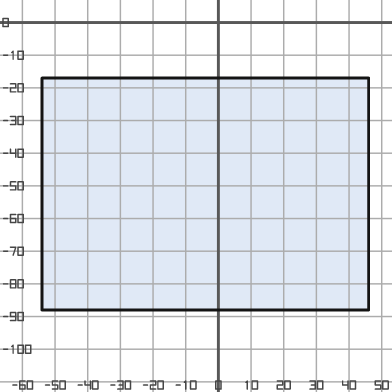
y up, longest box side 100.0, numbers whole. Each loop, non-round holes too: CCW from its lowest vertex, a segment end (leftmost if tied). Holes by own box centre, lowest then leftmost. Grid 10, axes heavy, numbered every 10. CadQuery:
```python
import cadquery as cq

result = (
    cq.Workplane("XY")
    .moveTo(-54.0, -88.0)
    .lineTo(46.0, -88.0)
    .lineTo(46.0, -17.0)
    .lineTo(-54.0, -17.0)
    .close()
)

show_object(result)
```